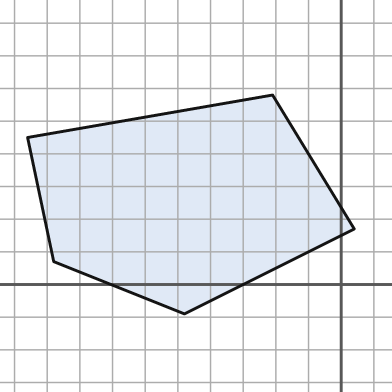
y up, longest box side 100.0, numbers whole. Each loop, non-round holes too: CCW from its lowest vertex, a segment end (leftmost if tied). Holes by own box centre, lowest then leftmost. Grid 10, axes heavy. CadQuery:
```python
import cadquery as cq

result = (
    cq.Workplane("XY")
    .moveTo(-48.0, -9.0)
    .lineTo(4.0, 17.0)
    .lineTo(-21.0, 58.0)
    .lineTo(-96.0, 45.0)
    .lineTo(-88.0, 7.0)
    .close()
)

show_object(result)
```